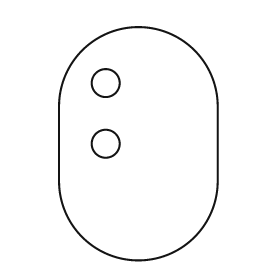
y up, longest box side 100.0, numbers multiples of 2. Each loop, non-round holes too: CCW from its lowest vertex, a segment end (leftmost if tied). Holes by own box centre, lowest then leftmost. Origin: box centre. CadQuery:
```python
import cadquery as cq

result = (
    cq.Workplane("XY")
    .moveTo(-34.0, -16.0)
    .threePointArc((0.0, -50.0), (34.0, -16.0))
    .lineTo(34.0, 16.0)
    .threePointArc((0.0, 50.0), (-34.0, 16.0))
    .close()
    .moveTo(-14.0, 0.0)
    .circle(6.0)
    .moveTo(-14.0, 26.0)
    .circle(6.0)
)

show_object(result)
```